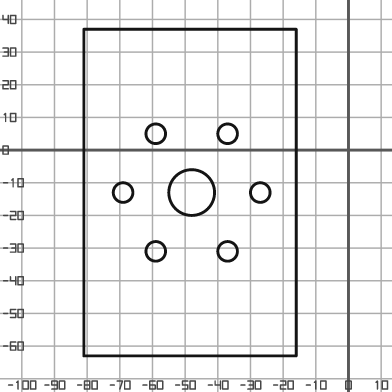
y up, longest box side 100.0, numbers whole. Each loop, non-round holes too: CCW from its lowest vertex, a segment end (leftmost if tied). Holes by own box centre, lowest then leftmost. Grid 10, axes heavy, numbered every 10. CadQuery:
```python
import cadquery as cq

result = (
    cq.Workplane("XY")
    .moveTo(-81.0, -63.0)
    .lineTo(-16.0, -63.0)
    .lineTo(-16.0, 37.0)
    .lineTo(-81.0, 37.0)
    .close()
    .moveTo(-59.0, -31.0)
    .circle(3.0)
    .moveTo(-37.0, -31.0)
    .circle(3.0)
    .moveTo(-69.0, -13.0)
    .circle(3.0)
    .moveTo(-48.0, -13.0)
    .circle(7.0)
    .moveTo(-27.0, -13.0)
    .circle(3.0)
    .moveTo(-59.0, 5.0)
    .circle(3.0)
    .moveTo(-37.0, 5.0)
    .circle(3.0)
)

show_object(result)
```